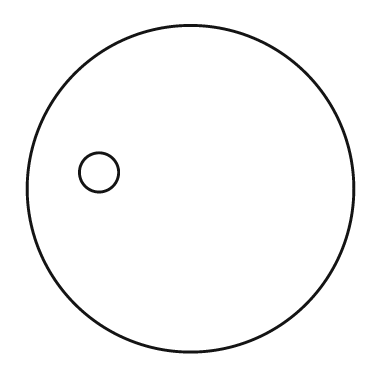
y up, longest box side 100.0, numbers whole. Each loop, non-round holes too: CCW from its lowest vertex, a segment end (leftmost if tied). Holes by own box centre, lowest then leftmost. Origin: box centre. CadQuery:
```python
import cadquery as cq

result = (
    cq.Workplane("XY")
    .moveTo(0.0, 0.0)
    .circle(50.0)
    .moveTo(-28.0, 5.0)
    .circle(6.0)
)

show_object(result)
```